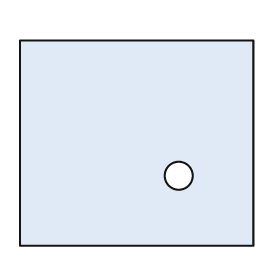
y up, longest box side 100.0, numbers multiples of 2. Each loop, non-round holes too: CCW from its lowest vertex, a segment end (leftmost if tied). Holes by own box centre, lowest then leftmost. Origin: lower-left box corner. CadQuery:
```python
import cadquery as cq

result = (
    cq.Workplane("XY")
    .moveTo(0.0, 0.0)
    .lineTo(100.0, 0.0)
    .lineTo(100.0, 88.0)
    .lineTo(0.0, 88.0)
    .close()
    .moveTo(68.0, 30.0)
    .circle(6.0)
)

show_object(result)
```